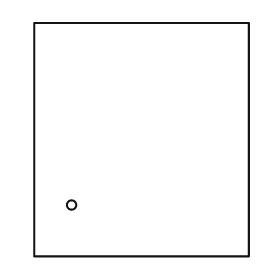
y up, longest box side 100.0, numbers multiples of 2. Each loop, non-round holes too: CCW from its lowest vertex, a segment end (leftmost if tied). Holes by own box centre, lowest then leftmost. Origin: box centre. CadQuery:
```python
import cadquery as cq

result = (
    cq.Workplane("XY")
    .moveTo(-46.0, -50.0)
    .lineTo(46.0, -50.0)
    .lineTo(46.0, 50.0)
    .lineTo(-46.0, 50.0)
    .close()
    .moveTo(-30.0, -28.0)
    .circle(2.0)
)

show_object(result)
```